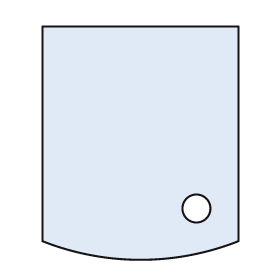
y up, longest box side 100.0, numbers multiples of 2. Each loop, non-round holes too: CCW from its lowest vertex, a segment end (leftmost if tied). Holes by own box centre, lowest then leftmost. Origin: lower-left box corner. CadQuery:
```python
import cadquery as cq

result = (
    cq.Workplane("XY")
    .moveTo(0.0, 8.0)
    .threePointArc((42.0, 0.0), (84.0, 8.0))
    .lineTo(84.0, 100.0)
    .lineTo(0.0, 100.0)
    .close()
    .moveTo(66.0, 22.0)
    .circle(6.0)
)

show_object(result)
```